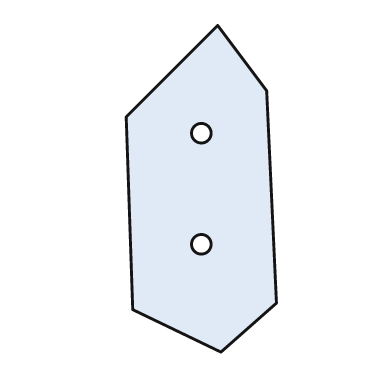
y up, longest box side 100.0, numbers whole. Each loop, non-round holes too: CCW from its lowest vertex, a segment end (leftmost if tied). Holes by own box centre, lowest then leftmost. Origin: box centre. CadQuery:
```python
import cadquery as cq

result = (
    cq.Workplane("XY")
    .moveTo(6.0, -50.0)
    .lineTo(23.0, -35.0)
    .lineTo(20.0, 30.0)
    .lineTo(5.0, 50.0)
    .lineTo(-23.0, 22.0)
    .lineTo(-21.0, -37.0)
    .close()
    .moveTo(0.0, -17.0)
    .circle(3.0)
    .moveTo(0.0, 17.0)
    .circle(3.0)
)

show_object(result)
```